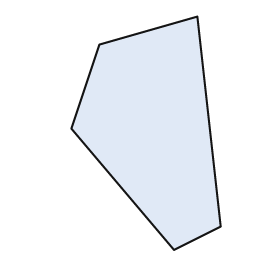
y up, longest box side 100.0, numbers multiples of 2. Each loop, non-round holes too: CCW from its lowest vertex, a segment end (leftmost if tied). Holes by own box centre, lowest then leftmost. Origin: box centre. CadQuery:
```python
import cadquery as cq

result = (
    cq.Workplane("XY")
    .moveTo(12.0, -50.0)
    .lineTo(32.0, -40.0)
    .lineTo(22.0, 50.0)
    .lineTo(-20.0, 38.0)
    .lineTo(-32.0, 2.0)
    .close()
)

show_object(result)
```